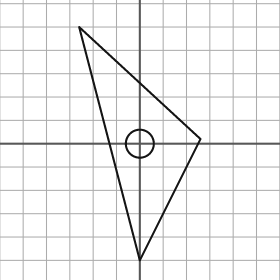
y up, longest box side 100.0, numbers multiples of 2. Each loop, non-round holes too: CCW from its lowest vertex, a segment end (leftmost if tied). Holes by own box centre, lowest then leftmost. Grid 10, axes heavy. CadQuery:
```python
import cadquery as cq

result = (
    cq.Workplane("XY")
    .moveTo(0.0, -50.0)
    .lineTo(26.0, 2.0)
    .lineTo(-26.0, 50.0)
    .close()
    .moveTo(0.0, 0.0)
    .circle(6.0)
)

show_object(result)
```